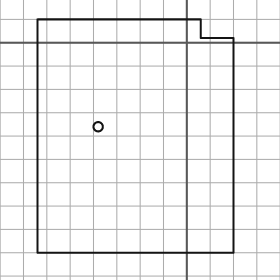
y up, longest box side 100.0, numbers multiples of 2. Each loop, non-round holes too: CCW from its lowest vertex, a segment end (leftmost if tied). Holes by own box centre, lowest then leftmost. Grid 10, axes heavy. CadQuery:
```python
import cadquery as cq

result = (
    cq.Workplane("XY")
    .moveTo(-64.0, -90.0)
    .lineTo(20.0, -90.0)
    .lineTo(20.0, 2.0)
    .lineTo(6.0, 2.0)
    .lineTo(6.0, 10.0)
    .lineTo(-64.0, 10.0)
    .close()
    .moveTo(-38.0, -36.0)
    .circle(2.0)
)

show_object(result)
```